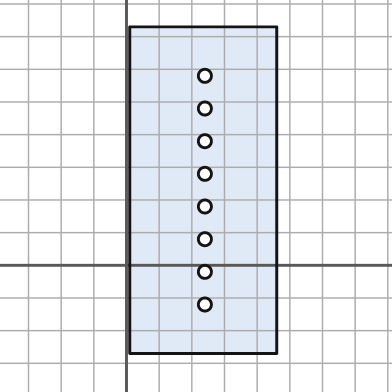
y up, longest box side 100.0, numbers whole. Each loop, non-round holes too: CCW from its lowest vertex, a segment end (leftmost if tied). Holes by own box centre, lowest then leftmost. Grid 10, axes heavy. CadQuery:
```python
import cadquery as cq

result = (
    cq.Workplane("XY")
    .moveTo(1.0, -27.0)
    .lineTo(46.0, -27.0)
    .lineTo(46.0, 73.0)
    .lineTo(1.0, 73.0)
    .close()
    .moveTo(24.0, -12.0)
    .circle(2.0)
    .moveTo(24.0, -2.0)
    .circle(2.0)
    .moveTo(24.0, 8.0)
    .circle(2.0)
    .moveTo(24.0, 18.0)
    .circle(2.0)
    .moveTo(24.0, 28.0)
    .circle(2.0)
    .moveTo(24.0, 38.0)
    .circle(2.0)
    .moveTo(24.0, 48.0)
    .circle(2.0)
    .moveTo(24.0, 58.0)
    .circle(2.0)
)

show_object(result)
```